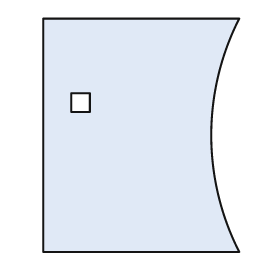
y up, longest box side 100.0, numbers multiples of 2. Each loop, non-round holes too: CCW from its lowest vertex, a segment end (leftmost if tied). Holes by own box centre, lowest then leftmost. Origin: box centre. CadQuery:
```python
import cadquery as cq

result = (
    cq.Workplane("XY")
    .moveTo(-42.0, -50.0)
    .lineTo(42.0, -50.0)
    .threePointArc((30.0, 0.0), (42.0, 50.0))
    .lineTo(-42.0, 50.0)
    .close()
    .moveTo(-30.0, 10.0)
    .lineTo(-22.0, 10.0)
    .lineTo(-22.0, 18.0)
    .lineTo(-30.0, 18.0)
    .close()
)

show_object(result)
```